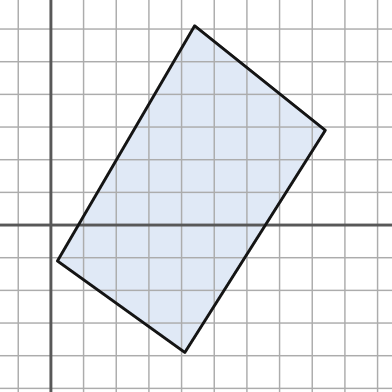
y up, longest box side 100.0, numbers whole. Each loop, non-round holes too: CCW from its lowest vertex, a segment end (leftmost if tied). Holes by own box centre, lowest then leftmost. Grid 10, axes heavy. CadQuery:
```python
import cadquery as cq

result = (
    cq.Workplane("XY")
    .moveTo(41.0, -39.0)
    .lineTo(84.0, 29.0)
    .lineTo(44.0, 61.0)
    .lineTo(2.0, -11.0)
    .close()
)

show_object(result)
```